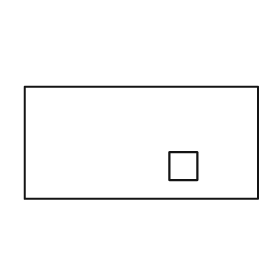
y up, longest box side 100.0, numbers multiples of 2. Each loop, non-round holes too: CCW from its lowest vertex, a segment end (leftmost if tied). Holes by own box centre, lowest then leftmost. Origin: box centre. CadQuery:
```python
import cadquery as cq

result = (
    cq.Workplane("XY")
    .moveTo(-50.0, -24.0)
    .lineTo(50.0, -24.0)
    .lineTo(50.0, 24.0)
    .lineTo(-50.0, 24.0)
    .close()
    .moveTo(12.0, -16.0)
    .lineTo(24.0, -16.0)
    .lineTo(24.0, -4.0)
    .lineTo(12.0, -4.0)
    .close()
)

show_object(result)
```